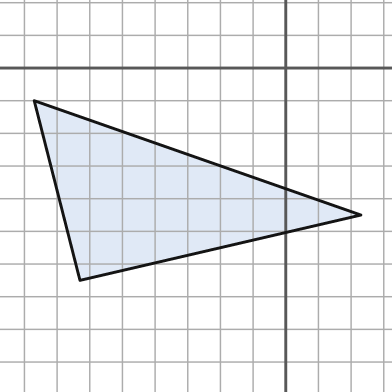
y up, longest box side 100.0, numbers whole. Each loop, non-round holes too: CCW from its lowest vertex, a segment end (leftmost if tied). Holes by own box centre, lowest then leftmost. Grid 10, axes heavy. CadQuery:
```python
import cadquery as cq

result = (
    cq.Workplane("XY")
    .moveTo(-63.0, -65.0)
    .lineTo(23.0, -45.0)
    .lineTo(-77.0, -10.0)
    .close()
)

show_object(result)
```